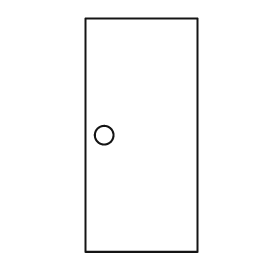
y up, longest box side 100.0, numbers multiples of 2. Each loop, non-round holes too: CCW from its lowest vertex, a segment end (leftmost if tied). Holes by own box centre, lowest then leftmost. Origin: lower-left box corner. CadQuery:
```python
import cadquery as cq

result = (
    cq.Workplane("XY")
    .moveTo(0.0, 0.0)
    .lineTo(48.0, 0.0)
    .lineTo(48.0, 100.0)
    .lineTo(0.0, 100.0)
    .close()
    .moveTo(8.0, 50.0)
    .circle(4.0)
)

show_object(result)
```